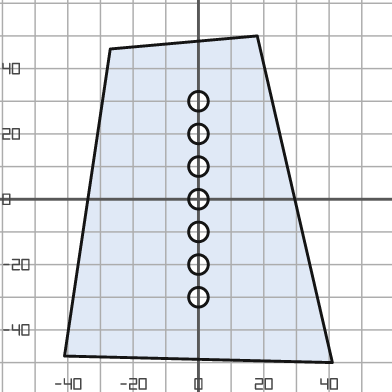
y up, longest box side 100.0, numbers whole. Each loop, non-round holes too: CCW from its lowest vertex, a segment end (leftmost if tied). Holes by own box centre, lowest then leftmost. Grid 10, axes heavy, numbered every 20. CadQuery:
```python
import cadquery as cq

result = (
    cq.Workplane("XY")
    .moveTo(41.0, -50.0)
    .lineTo(18.0, 50.0)
    .lineTo(-27.0, 46.0)
    .lineTo(-41.0, -48.0)
    .close()
    .moveTo(0.0, -30.0)
    .circle(3.0)
    .moveTo(0.0, -20.0)
    .circle(3.0)
    .moveTo(0.0, -10.0)
    .circle(3.0)
    .moveTo(0.0, 0.0)
    .circle(3.0)
    .moveTo(0.0, 10.0)
    .circle(3.0)
    .moveTo(0.0, 20.0)
    .circle(3.0)
    .moveTo(0.0, 30.0)
    .circle(3.0)
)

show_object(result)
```